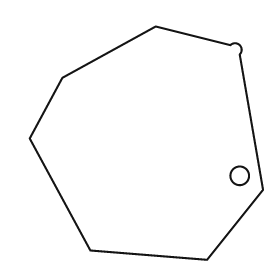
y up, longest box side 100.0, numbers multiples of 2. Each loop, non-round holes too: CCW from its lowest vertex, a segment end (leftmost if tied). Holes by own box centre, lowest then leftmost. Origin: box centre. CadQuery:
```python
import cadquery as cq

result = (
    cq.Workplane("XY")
    .moveTo(26.0, -50.0)
    .lineTo(50.0, -20.0)
    .lineTo(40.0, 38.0)
    .threePointArc((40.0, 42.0), (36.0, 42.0))
    .lineTo(4.0, 50.0)
    .lineTo(-36.0, 28.0)
    .lineTo(-50.0, 2.0)
    .lineTo(-24.0, -46.0)
    .close()
    .moveTo(40.0, -14.0)
    .circle(4.0)
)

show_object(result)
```